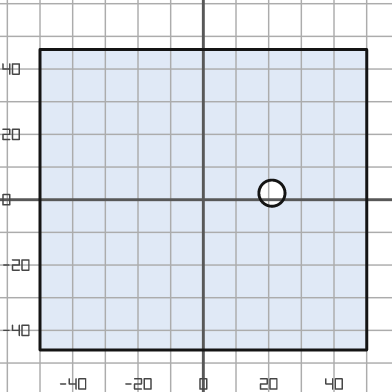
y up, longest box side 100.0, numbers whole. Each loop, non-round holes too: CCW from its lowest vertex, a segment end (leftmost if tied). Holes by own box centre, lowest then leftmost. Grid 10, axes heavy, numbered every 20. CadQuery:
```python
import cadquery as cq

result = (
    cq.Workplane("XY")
    .moveTo(-50.0, -46.0)
    .lineTo(50.0, -46.0)
    .lineTo(50.0, 46.0)
    .lineTo(-50.0, 46.0)
    .close()
    .moveTo(21.0, 2.0)
    .circle(4.0)
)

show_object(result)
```